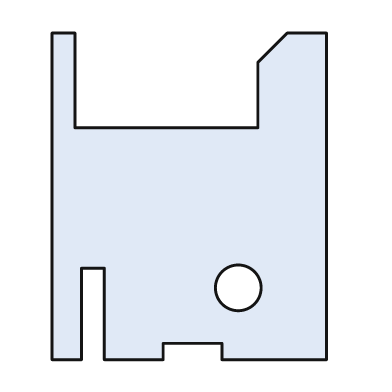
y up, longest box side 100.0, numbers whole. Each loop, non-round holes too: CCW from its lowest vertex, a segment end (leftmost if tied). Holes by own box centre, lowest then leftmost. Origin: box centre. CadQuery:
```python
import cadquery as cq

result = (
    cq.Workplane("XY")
    .moveTo(-42.0, -50.0)
    .lineTo(-33.0, -50.0)
    .lineTo(-33.0, -22.0)
    .lineTo(-26.0, -22.0)
    .lineTo(-26.0, -50.0)
    .lineTo(-8.0, -50.0)
    .lineTo(-8.0, -45.0)
    .lineTo(10.0, -45.0)
    .lineTo(10.0, -50.0)
    .lineTo(42.0, -50.0)
    .lineTo(42.0, 50.0)
    .lineTo(30.0, 50.0)
    .lineTo(21.0, 41.0)
    .lineTo(21.0, 21.0)
    .lineTo(-35.0, 21.0)
    .lineTo(-35.0, 50.0)
    .lineTo(-42.0, 50.0)
    .close()
    .moveTo(15.0, -28.0)
    .circle(7.0)
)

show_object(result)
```